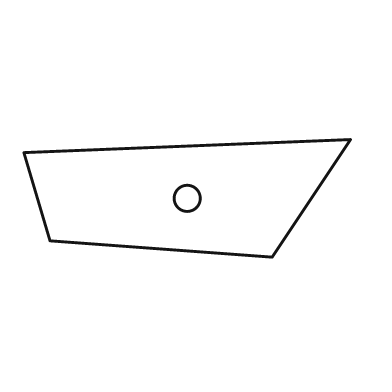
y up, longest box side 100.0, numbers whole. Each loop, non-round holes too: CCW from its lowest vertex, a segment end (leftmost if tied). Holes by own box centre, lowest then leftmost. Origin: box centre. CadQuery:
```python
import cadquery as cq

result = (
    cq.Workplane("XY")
    .moveTo(26.0, -18.0)
    .lineTo(50.0, 18.0)
    .lineTo(-50.0, 14.0)
    .lineTo(-42.0, -13.0)
    .close()
    .moveTo(0.0, 0.0)
    .circle(4.0)
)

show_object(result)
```